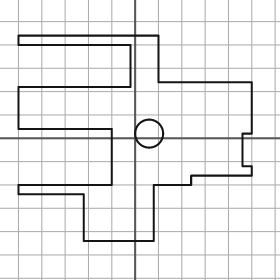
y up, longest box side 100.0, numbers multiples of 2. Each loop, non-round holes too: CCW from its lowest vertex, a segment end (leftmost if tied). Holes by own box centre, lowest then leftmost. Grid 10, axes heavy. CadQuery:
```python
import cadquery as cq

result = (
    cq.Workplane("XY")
    .moveTo(-22.0, -44.0)
    .lineTo(8.0, -44.0)
    .lineTo(8.0, -20.0)
    .lineTo(24.0, -20.0)
    .lineTo(24.0, -16.0)
    .lineTo(50.0, -16.0)
    .lineTo(50.0, -12.0)
    .lineTo(46.0, -12.0)
    .lineTo(46.0, 2.0)
    .lineTo(50.0, 2.0)
    .lineTo(50.0, 24.0)
    .lineTo(10.0, 24.0)
    .lineTo(10.0, 44.0)
    .lineTo(-50.0, 44.0)
    .lineTo(-50.0, 40.0)
    .lineTo(-2.0, 40.0)
    .lineTo(-2.0, 22.0)
    .lineTo(-50.0, 22.0)
    .lineTo(-50.0, 4.0)
    .lineTo(-10.0, 4.0)
    .lineTo(-10.0, -20.0)
    .lineTo(-50.0, -20.0)
    .lineTo(-50.0, -24.0)
    .lineTo(-22.0, -24.0)
    .close()
    .moveTo(6.0, 2.0)
    .circle(6.0)
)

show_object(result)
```